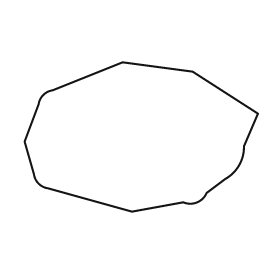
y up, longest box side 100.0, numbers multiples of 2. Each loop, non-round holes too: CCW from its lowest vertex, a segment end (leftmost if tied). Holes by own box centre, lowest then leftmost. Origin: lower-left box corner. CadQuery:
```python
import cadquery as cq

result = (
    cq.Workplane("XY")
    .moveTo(46.0, 0.0)
    .lineTo(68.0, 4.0)
    .threePointArc((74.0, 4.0), (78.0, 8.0))
    .lineTo(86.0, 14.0)
    .threePointArc((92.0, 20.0), (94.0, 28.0))
    .lineTo(100.0, 42.0)
    .lineTo(72.0, 60.0)
    .lineTo(42.0, 64.0)
    .lineTo(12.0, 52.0)
    .threePointArc((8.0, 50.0), (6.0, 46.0))
    .lineTo(0.0, 30.0)
    .lineTo(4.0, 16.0)
    .threePointArc((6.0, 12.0), (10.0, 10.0))
    .close()
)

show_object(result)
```